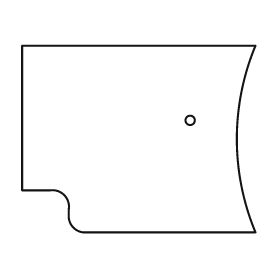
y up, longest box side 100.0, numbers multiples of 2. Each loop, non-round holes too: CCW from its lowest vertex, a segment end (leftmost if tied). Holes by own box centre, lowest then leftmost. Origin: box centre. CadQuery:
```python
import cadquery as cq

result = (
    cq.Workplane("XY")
    .moveTo(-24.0, -40.0)
    .lineTo(50.0, -40.0)
    .threePointArc((42.0, 0.0), (50.0, 40.0))
    .lineTo(-50.0, 40.0)
    .lineTo(-50.0, -22.0)
    .lineTo(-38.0, -22.0)
    .threePointArc((-32.0, -24.0), (-30.0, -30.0))
    .lineTo(-30.0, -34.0)
    .threePointArc((-28.0, -38.0), (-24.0, -40.0))
    .close()
    .moveTo(22.0, 8.0)
    .circle(2.0)
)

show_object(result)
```